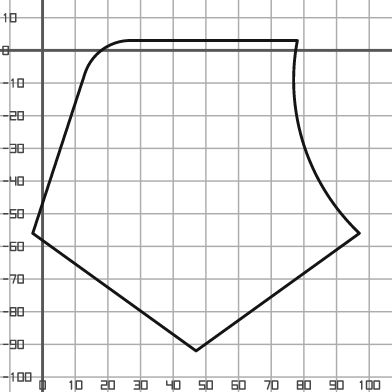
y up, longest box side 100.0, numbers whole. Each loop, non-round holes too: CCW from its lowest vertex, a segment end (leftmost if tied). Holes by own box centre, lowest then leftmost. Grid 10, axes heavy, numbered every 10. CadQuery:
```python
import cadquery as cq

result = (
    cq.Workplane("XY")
    .moveTo(47.0, -92.0)
    .lineTo(97.0, -56.0)
    .threePointArc((80.0, -29.0), (78.0, 3.0))
    .lineTo(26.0, 3.0)
    .threePointArc((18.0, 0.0), (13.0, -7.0))
    .lineTo(-3.0, -56.0)
    .close()
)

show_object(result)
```